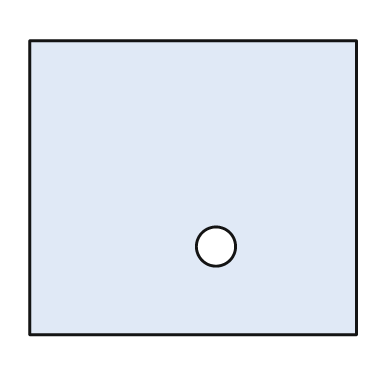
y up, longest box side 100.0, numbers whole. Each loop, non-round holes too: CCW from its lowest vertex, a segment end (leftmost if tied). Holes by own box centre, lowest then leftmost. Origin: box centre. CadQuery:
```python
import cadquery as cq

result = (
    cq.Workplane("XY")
    .moveTo(-50.0, -45.0)
    .lineTo(50.0, -45.0)
    .lineTo(50.0, 45.0)
    .lineTo(-50.0, 45.0)
    .close()
    .moveTo(7.0, -18.0)
    .circle(6.0)
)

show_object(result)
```